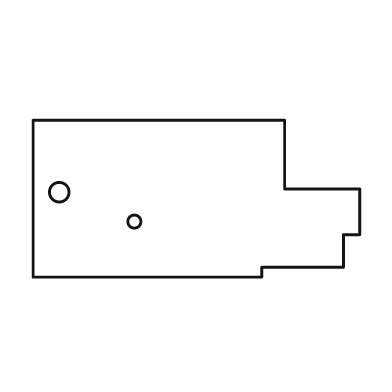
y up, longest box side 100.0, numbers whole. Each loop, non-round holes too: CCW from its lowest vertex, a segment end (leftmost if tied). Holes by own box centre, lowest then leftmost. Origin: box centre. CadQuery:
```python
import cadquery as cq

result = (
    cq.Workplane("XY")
    .moveTo(-50.0, -24.0)
    .lineTo(20.0, -24.0)
    .lineTo(20.0, -21.0)
    .lineTo(45.0, -21.0)
    .lineTo(45.0, -11.0)
    .lineTo(50.0, -11.0)
    .lineTo(50.0, 3.0)
    .lineTo(27.0, 3.0)
    .lineTo(27.0, 24.0)
    .lineTo(-50.0, 24.0)
    .close()
    .moveTo(-19.0, -7.0)
    .circle(2.0)
    .moveTo(-42.0, 2.0)
    .circle(3.0)
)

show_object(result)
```